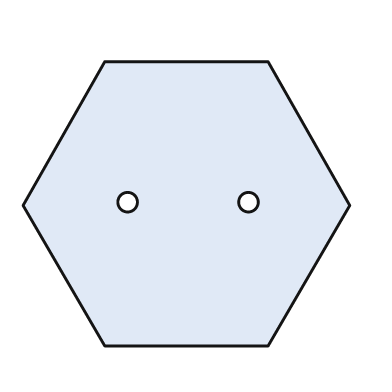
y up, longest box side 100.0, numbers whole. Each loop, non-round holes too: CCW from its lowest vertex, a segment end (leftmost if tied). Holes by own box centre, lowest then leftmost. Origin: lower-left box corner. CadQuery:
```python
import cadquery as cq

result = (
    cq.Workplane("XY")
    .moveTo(25.0, 0.0)
    .lineTo(75.0, 0.0)
    .lineTo(100.0, 43.0)
    .lineTo(75.0, 87.0)
    .lineTo(25.0, 87.0)
    .lineTo(0.0, 43.0)
    .close()
    .moveTo(32.0, 44.0)
    .circle(3.0)
    .moveTo(69.0, 44.0)
    .circle(3.0)
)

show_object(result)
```